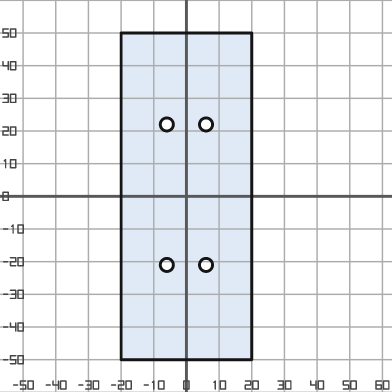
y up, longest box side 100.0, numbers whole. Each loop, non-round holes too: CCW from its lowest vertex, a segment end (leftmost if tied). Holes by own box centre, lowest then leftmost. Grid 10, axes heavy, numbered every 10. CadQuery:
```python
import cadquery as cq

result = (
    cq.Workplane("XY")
    .moveTo(-20.0, -50.0)
    .lineTo(20.0, -50.0)
    .lineTo(20.0, 50.0)
    .lineTo(-20.0, 50.0)
    .close()
    .moveTo(-6.0, -21.0)
    .circle(2.0)
    .moveTo(6.0, -21.0)
    .circle(2.0)
    .moveTo(-6.0, 22.0)
    .circle(2.0)
    .moveTo(6.0, 22.0)
    .circle(2.0)
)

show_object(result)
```